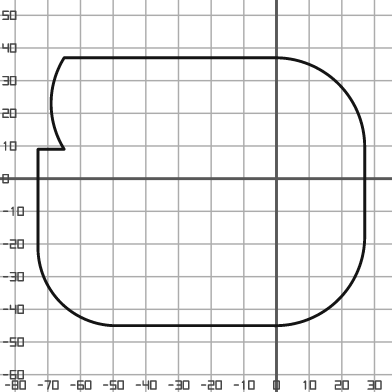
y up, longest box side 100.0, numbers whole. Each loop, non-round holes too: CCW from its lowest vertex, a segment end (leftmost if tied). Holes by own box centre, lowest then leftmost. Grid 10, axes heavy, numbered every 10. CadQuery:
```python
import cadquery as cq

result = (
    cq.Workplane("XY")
    .moveTo(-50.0, -45.0)
    .lineTo(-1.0, -45.0)
    .threePointArc((19.0, -37.0), (27.0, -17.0))
    .lineTo(27.0, 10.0)
    .threePointArc((19.0, 29.0), (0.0, 37.0))
    .lineTo(-65.0, 37.0)
    .threePointArc((-69.0, 23.0), (-65.0, 9.0))
    .lineTo(-73.0, 9.0)
    .lineTo(-73.0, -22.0)
    .threePointArc((-66.0, -38.0), (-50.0, -45.0))
    .close()
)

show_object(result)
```